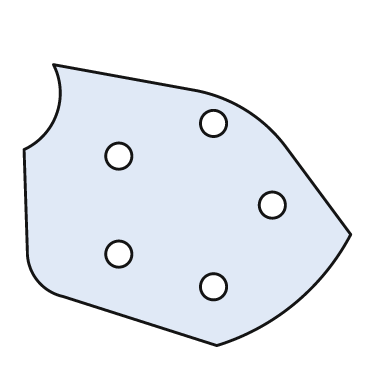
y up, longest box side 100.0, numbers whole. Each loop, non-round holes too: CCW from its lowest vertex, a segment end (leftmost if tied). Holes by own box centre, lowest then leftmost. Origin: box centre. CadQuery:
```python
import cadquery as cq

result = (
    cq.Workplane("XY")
    .moveTo(9.0, -43.0)
    .threePointArc((33.0, -30.0), (50.0, -9.0))
    .lineTo(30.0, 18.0)
    .threePointArc((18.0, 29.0), (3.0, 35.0))
    .lineTo(-41.0, 43.0)
    .threePointArc((-40.0, 28.0), (-50.0, 17.0))
    .lineTo(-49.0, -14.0)
    .threePointArc((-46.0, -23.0), (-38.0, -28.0))
    .close()
    .moveTo(8.0, -25.0)
    .circle(4.0)
    .moveTo(-21.0, -15.0)
    .circle(4.0)
    .moveTo(26.0, 0.0)
    .circle(4.0)
    .moveTo(-21.0, 15.0)
    .circle(4.0)
    .moveTo(8.0, 25.0)
    .circle(4.0)
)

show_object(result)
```